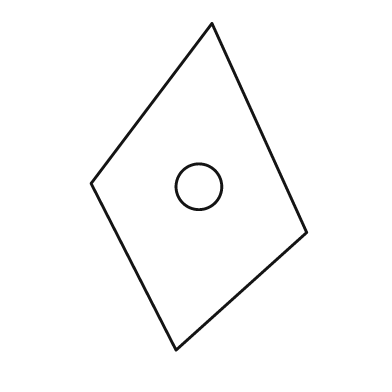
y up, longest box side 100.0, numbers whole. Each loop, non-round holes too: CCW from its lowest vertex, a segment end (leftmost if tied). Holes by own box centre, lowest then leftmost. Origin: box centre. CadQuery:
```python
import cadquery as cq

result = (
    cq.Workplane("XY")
    .moveTo(-7.0, -50.0)
    .lineTo(33.0, -14.0)
    .lineTo(4.0, 50.0)
    .lineTo(-33.0, 1.0)
    .close()
    .moveTo(0.0, 0.0)
    .circle(7.0)
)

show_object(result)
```